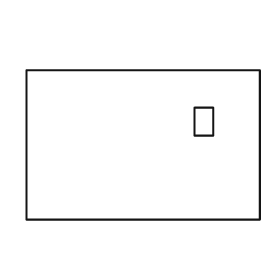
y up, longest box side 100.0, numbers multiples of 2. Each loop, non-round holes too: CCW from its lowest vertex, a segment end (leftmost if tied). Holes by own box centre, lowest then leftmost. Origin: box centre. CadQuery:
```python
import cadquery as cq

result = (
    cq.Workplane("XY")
    .moveTo(-50.0, -32.0)
    .lineTo(50.0, -32.0)
    .lineTo(50.0, 32.0)
    .lineTo(-50.0, 32.0)
    .close()
    .moveTo(22.0, 4.0)
    .lineTo(30.0, 4.0)
    .lineTo(30.0, 16.0)
    .lineTo(22.0, 16.0)
    .close()
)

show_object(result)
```